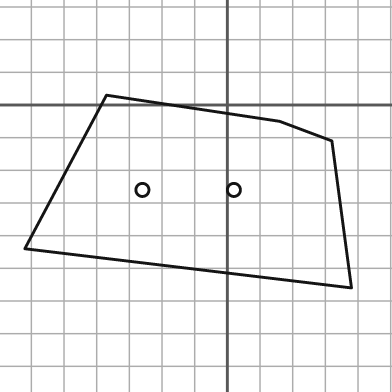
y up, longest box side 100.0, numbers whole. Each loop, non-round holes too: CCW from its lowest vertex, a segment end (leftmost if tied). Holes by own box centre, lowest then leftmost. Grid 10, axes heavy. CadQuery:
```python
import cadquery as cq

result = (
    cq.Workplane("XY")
    .moveTo(38.0, -56.0)
    .lineTo(32.0, -11.0)
    .lineTo(16.0, -5.0)
    .lineTo(-37.0, 3.0)
    .lineTo(-62.0, -44.0)
    .close()
    .moveTo(-26.0, -26.0)
    .circle(2.0)
    .moveTo(2.0, -26.0)
    .circle(2.0)
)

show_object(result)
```